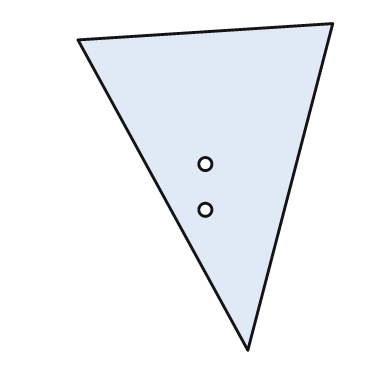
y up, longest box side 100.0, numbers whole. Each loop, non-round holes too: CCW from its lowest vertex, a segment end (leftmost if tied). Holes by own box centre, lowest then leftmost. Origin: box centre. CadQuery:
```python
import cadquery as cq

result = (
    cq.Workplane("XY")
    .moveTo(13.0, -50.0)
    .lineTo(39.0, 50.0)
    .lineTo(-39.0, 45.0)
    .close()
    .moveTo(0.0, -7.0)
    .circle(2.0)
    .moveTo(0.0, 7.0)
    .circle(2.0)
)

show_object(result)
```